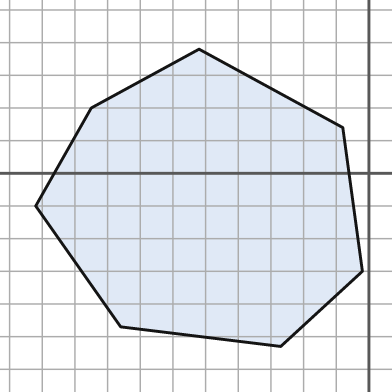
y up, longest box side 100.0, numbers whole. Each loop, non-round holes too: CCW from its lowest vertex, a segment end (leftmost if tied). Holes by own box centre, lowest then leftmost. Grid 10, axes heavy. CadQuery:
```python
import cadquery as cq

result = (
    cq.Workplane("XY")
    .moveTo(-27.0, -53.0)
    .lineTo(-2.0, -30.0)
    .lineTo(-8.0, 14.0)
    .lineTo(-52.0, 38.0)
    .lineTo(-85.0, 20.0)
    .lineTo(-102.0, -10.0)
    .lineTo(-76.0, -47.0)
    .close()
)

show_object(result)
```